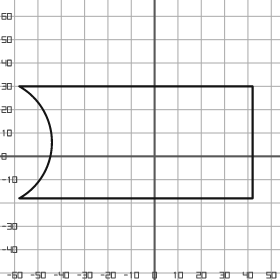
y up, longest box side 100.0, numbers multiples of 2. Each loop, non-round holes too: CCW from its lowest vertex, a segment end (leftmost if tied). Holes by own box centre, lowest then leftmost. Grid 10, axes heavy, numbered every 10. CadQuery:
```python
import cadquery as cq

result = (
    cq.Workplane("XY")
    .moveTo(-58.0, -18.0)
    .lineTo(42.0, -18.0)
    .lineTo(42.0, 30.0)
    .lineTo(-58.0, 30.0)
    .threePointArc((-44.0, 6.0), (-58.0, -18.0))
    .close()
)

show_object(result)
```